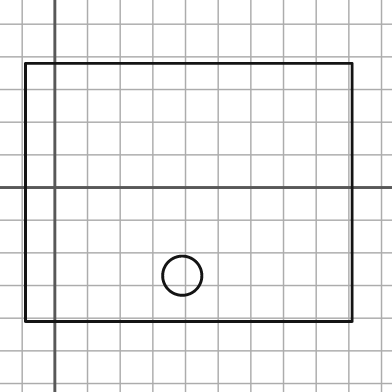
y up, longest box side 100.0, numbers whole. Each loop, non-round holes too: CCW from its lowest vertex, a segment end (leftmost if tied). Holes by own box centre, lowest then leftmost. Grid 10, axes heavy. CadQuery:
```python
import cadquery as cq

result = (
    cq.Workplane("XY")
    .moveTo(-9.0, -41.0)
    .lineTo(91.0, -41.0)
    .lineTo(91.0, 38.0)
    .lineTo(-9.0, 38.0)
    .close()
    .moveTo(39.0, -27.0)
    .circle(6.0)
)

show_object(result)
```